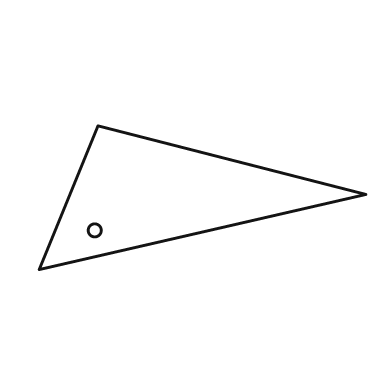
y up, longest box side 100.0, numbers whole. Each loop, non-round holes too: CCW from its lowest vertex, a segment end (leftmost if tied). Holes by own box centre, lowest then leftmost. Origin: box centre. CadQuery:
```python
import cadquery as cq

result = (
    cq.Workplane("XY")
    .moveTo(-50.0, -22.0)
    .lineTo(50.0, 1.0)
    .lineTo(-32.0, 22.0)
    .close()
    .moveTo(-33.0, -10.0)
    .circle(2.0)
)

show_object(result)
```